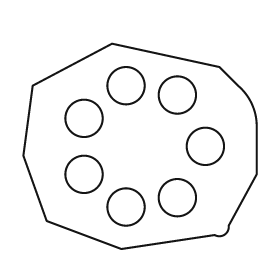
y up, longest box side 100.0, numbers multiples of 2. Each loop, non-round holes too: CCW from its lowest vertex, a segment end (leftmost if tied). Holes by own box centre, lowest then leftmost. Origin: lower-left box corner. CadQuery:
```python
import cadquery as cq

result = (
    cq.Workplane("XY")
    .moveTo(42.0, 0.0)
    .lineTo(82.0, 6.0)
    .threePointArc((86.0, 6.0), (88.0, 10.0))
    .lineTo(100.0, 32.0)
    .lineTo(100.0, 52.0)
    .threePointArc((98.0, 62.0), (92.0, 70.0))
    .lineTo(84.0, 78.0)
    .lineTo(38.0, 88.0)
    .lineTo(4.0, 70.0)
    .lineTo(0.0, 40.0)
    .lineTo(10.0, 12.0)
    .close()
    .moveTo(44.0, 18.0)
    .circle(8.0)
    .moveTo(66.0, 22.0)
    .circle(8.0)
    .moveTo(26.0, 32.0)
    .circle(8.0)
    .moveTo(78.0, 44.0)
    .circle(8.0)
    .moveTo(26.0, 56.0)
    .circle(8.0)
    .moveTo(66.0, 66.0)
    .circle(8.0)
    .moveTo(44.0, 70.0)
    .circle(8.0)
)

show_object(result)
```